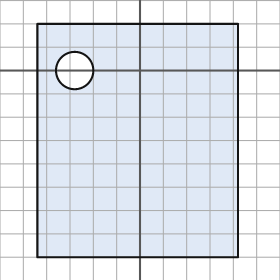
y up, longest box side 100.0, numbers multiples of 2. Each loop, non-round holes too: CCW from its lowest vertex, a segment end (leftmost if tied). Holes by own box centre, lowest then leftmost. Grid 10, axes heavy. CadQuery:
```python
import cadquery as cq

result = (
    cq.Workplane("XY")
    .moveTo(-44.0, -80.0)
    .lineTo(42.0, -80.0)
    .lineTo(42.0, 20.0)
    .lineTo(-44.0, 20.0)
    .close()
    .moveTo(-28.0, 0.0)
    .circle(8.0)
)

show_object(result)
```